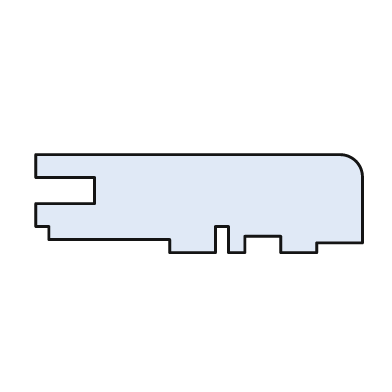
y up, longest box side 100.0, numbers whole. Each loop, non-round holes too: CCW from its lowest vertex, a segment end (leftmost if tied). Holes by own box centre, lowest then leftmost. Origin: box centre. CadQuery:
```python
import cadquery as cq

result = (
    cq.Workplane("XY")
    .moveTo(-9.0, -15.0)
    .lineTo(5.0, -15.0)
    .lineTo(5.0, -7.0)
    .lineTo(9.0, -7.0)
    .lineTo(9.0, -15.0)
    .lineTo(14.0, -15.0)
    .lineTo(14.0, -10.0)
    .lineTo(25.0, -10.0)
    .lineTo(25.0, -15.0)
    .lineTo(36.0, -15.0)
    .lineTo(36.0, -12.0)
    .lineTo(50.0, -12.0)
    .lineTo(50.0, 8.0)
    .threePointArc((48.0, 13.0), (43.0, 15.0))
    .lineTo(-50.0, 15.0)
    .lineTo(-50.0, 8.0)
    .lineTo(-32.0, 8.0)
    .lineTo(-32.0, 0.0)
    .lineTo(-50.0, 0.0)
    .lineTo(-50.0, -7.0)
    .lineTo(-46.0, -7.0)
    .lineTo(-46.0, -11.0)
    .lineTo(-9.0, -11.0)
    .close()
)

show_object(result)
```